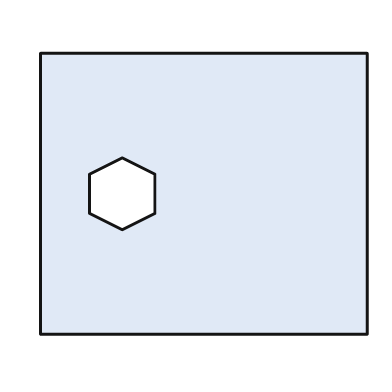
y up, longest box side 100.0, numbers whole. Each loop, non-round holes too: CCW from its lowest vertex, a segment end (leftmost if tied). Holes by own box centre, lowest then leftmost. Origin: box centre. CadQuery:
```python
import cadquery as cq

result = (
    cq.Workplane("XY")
    .moveTo(-50.0, -43.0)
    .lineTo(50.0, -43.0)
    .lineTo(50.0, 43.0)
    .lineTo(-50.0, 43.0)
    .close()
    .moveTo(-25.0, -11.0)
    .lineTo(-15.0, -6.0)
    .lineTo(-15.0, 6.0)
    .lineTo(-25.0, 11.0)
    .lineTo(-35.0, 6.0)
    .lineTo(-35.0, -6.0)
    .close()
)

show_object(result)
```